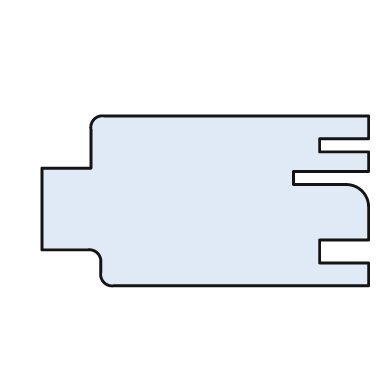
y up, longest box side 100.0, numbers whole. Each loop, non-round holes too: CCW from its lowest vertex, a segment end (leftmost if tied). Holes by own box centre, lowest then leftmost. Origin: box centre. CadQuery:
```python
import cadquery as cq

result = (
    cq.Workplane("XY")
    .moveTo(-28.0, -26.0)
    .lineTo(50.0, -26.0)
    .lineTo(50.0, -19.0)
    .lineTo(35.0, -19.0)
    .lineTo(35.0, -12.0)
    .lineTo(50.0, -12.0)
    .lineTo(50.0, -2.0)
    .threePointArc((48.0, 3.0), (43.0, 5.0))
    .lineTo(27.0, 5.0)
    .lineTo(27.0, 9.0)
    .lineTo(50.0, 9.0)
    .lineTo(50.0, 15.0)
    .lineTo(35.0, 15.0)
    .lineTo(35.0, 19.0)
    .lineTo(50.0, 19.0)
    .lineTo(50.0, 26.0)
    .lineTo(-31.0, 26.0)
    .threePointArc((-34.0, 25.0), (-35.0, 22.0))
    .lineTo(-35.0, 10.0)
    .lineTo(-50.0, 10.0)
    .lineTo(-50.0, -15.0)
    .lineTo(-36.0, -15.0)
    .threePointArc((-33.0, -16.0), (-32.0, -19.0))
    .lineTo(-32.0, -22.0)
    .threePointArc((-31.0, -25.0), (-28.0, -26.0))
    .close()
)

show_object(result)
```